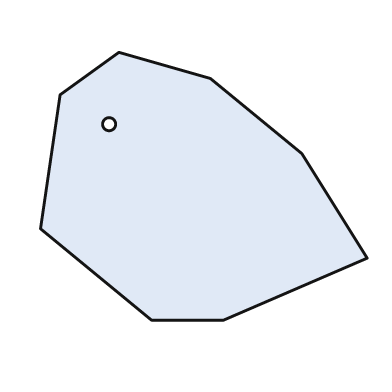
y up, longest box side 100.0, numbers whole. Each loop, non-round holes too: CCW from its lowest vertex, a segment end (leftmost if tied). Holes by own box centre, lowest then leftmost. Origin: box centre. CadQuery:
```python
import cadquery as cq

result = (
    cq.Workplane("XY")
    .moveTo(-16.0, -41.0)
    .lineTo(6.0, -41.0)
    .lineTo(50.0, -22.0)
    .lineTo(30.0, 10.0)
    .lineTo(2.0, 33.0)
    .lineTo(-26.0, 41.0)
    .lineTo(-44.0, 28.0)
    .lineTo(-50.0, -13.0)
    .close()
    .moveTo(-29.0, 19.0)
    .circle(2.0)
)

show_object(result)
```